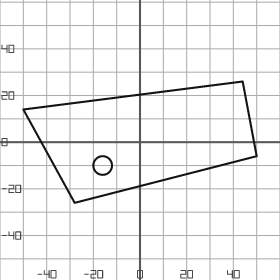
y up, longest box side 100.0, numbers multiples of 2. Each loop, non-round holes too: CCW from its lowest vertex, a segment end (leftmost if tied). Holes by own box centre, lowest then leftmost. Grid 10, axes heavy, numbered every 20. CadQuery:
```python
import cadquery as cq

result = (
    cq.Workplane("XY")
    .moveTo(-28.0, -26.0)
    .lineTo(50.0, -6.0)
    .lineTo(44.0, 26.0)
    .lineTo(-50.0, 14.0)
    .close()
    .moveTo(-16.0, -10.0)
    .circle(4.0)
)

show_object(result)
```